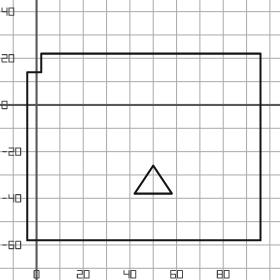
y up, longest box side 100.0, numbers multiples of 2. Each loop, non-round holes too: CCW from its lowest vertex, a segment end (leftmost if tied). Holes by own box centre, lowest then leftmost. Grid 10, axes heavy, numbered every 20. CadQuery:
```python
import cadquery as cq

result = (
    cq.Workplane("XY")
    .moveTo(-4.0, -58.0)
    .lineTo(96.0, -58.0)
    .lineTo(96.0, 22.0)
    .lineTo(2.0, 22.0)
    .lineTo(2.0, 14.0)
    .lineTo(-4.0, 14.0)
    .close()
    .moveTo(42.0, -38.0)
    .lineTo(58.0, -38.0)
    .lineTo(50.0, -26.0)
    .close()
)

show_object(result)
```